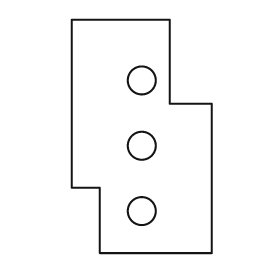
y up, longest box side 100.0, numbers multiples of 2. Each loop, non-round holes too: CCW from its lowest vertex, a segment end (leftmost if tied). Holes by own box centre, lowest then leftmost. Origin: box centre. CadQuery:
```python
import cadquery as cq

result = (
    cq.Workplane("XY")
    .moveTo(-18.0, -50.0)
    .lineTo(30.0, -50.0)
    .lineTo(30.0, 14.0)
    .lineTo(12.0, 14.0)
    .lineTo(12.0, 50.0)
    .lineTo(-30.0, 50.0)
    .lineTo(-30.0, -22.0)
    .lineTo(-18.0, -22.0)
    .close()
    .moveTo(0.0, -32.0)
    .circle(6.0)
    .moveTo(0.0, -4.0)
    .circle(6.0)
    .moveTo(0.0, 24.0)
    .circle(6.0)
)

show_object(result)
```